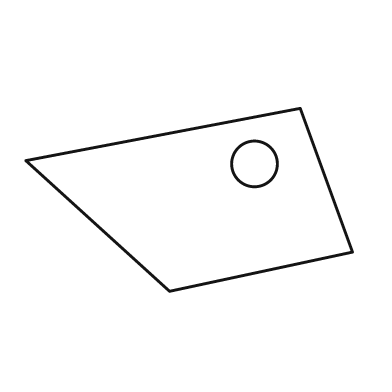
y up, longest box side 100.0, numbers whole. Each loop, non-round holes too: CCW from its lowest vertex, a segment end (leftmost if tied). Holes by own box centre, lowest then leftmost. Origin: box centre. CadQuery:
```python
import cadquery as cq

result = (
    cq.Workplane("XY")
    .moveTo(-6.0, -28.0)
    .lineTo(50.0, -16.0)
    .lineTo(34.0, 28.0)
    .lineTo(-50.0, 12.0)
    .close()
    .moveTo(20.0, 11.0)
    .circle(7.0)
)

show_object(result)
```